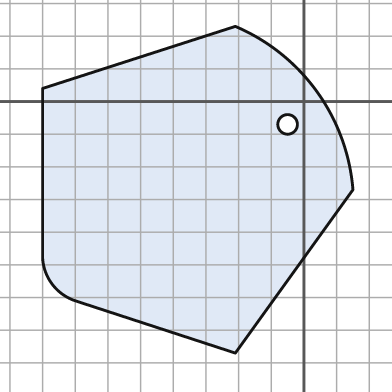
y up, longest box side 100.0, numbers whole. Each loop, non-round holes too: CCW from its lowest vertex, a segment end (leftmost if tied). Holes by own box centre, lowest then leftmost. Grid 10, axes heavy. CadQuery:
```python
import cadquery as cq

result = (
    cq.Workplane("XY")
    .moveTo(-21.0, -77.0)
    .lineTo(15.0, -27.0)
    .threePointArc((4.0, 3.0), (-21.0, 23.0))
    .lineTo(-80.0, 4.0)
    .lineTo(-80.0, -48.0)
    .threePointArc((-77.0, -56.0), (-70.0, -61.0))
    .close()
    .moveTo(-5.0, -7.0)
    .circle(3.0)
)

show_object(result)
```